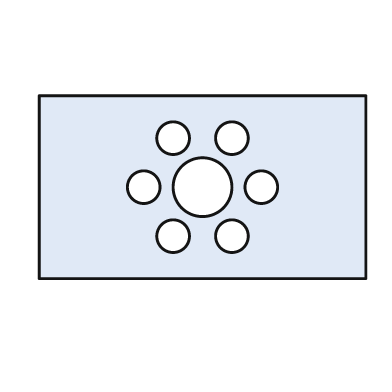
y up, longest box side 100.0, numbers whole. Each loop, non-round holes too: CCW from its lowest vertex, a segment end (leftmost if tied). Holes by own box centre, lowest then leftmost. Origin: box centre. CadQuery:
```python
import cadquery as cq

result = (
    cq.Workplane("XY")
    .moveTo(-50.0, -28.0)
    .lineTo(50.0, -28.0)
    .lineTo(50.0, 28.0)
    .lineTo(-50.0, 28.0)
    .close()
    .moveTo(-9.0, -15.0)
    .circle(5.0)
    .moveTo(9.0, -15.0)
    .circle(5.0)
    .moveTo(-18.0, 0.0)
    .circle(5.0)
    .moveTo(0.0, 0.0)
    .circle(9.0)
    .moveTo(18.0, 0.0)
    .circle(5.0)
    .moveTo(-9.0, 15.0)
    .circle(5.0)
    .moveTo(9.0, 15.0)
    .circle(5.0)
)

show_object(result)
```